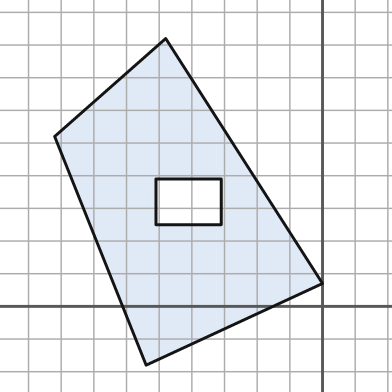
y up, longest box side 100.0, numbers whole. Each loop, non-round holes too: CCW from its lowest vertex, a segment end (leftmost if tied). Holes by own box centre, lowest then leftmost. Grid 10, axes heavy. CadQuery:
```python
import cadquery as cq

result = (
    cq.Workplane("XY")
    .moveTo(-54.0, -18.0)
    .lineTo(0.0, 7.0)
    .lineTo(-48.0, 82.0)
    .lineTo(-82.0, 52.0)
    .close()
    .moveTo(-51.0, 25.0)
    .lineTo(-31.0, 25.0)
    .lineTo(-31.0, 39.0)
    .lineTo(-51.0, 39.0)
    .close()
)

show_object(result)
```